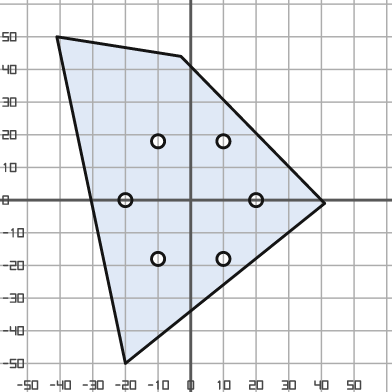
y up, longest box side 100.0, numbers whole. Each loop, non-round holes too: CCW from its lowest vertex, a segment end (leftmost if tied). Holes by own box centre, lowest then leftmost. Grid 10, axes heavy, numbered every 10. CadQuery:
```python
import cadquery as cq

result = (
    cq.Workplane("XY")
    .moveTo(-20.0, -50.0)
    .lineTo(41.0, -1.0)
    .lineTo(-3.0, 44.0)
    .lineTo(-41.0, 50.0)
    .close()
    .moveTo(-10.0, -18.0)
    .circle(2.0)
    .moveTo(10.0, -18.0)
    .circle(2.0)
    .moveTo(-20.0, 0.0)
    .circle(2.0)
    .moveTo(20.0, 0.0)
    .circle(2.0)
    .moveTo(-10.0, 18.0)
    .circle(2.0)
    .moveTo(10.0, 18.0)
    .circle(2.0)
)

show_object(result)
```